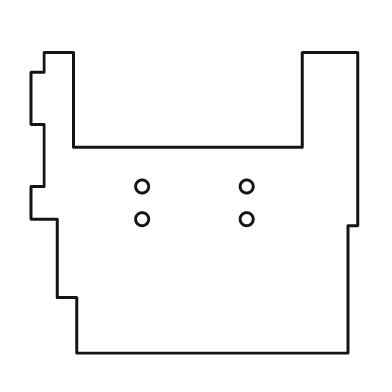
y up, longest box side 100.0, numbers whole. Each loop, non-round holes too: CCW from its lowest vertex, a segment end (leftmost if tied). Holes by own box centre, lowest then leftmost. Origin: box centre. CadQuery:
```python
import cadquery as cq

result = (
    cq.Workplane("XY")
    .moveTo(-36.0, -46.0)
    .lineTo(47.0, -46.0)
    .lineTo(47.0, -7.0)
    .lineTo(50.0, -7.0)
    .lineTo(50.0, 46.0)
    .lineTo(33.0, 46.0)
    .lineTo(33.0, 17.0)
    .lineTo(-37.0, 17.0)
    .lineTo(-37.0, 46.0)
    .lineTo(-46.0, 46.0)
    .lineTo(-46.0, 40.0)
    .lineTo(-50.0, 40.0)
    .lineTo(-50.0, 24.0)
    .lineTo(-46.0, 24.0)
    .lineTo(-46.0, 5.0)
    .lineTo(-50.0, 5.0)
    .lineTo(-50.0, -5.0)
    .lineTo(-42.0, -5.0)
    .lineTo(-42.0, -29.0)
    .lineTo(-36.0, -29.0)
    .close()
    .moveTo(-16.0, -5.0)
    .circle(2.0)
    .moveTo(16.0, -5.0)
    .circle(2.0)
    .moveTo(-16.0, 5.0)
    .circle(2.0)
    .moveTo(16.0, 5.0)
    .circle(2.0)
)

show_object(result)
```